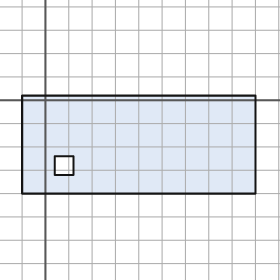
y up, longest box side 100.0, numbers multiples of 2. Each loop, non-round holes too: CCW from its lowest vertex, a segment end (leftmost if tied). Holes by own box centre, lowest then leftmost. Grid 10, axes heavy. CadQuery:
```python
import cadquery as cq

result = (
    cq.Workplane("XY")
    .moveTo(-10.0, -40.0)
    .lineTo(90.0, -40.0)
    .lineTo(90.0, 2.0)
    .lineTo(-10.0, 2.0)
    .close()
    .moveTo(4.0, -32.0)
    .lineTo(12.0, -32.0)
    .lineTo(12.0, -24.0)
    .lineTo(4.0, -24.0)
    .close()
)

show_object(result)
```